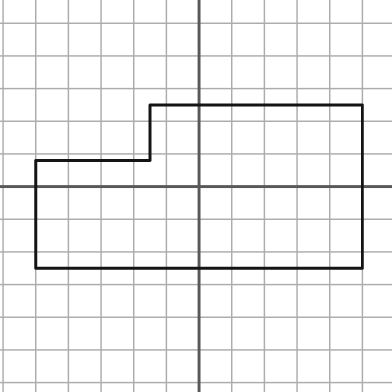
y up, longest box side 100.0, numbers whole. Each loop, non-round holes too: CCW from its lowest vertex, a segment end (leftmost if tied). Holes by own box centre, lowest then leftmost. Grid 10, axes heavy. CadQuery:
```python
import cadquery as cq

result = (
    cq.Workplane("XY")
    .moveTo(-50.0, -25.0)
    .lineTo(50.0, -25.0)
    .lineTo(50.0, 25.0)
    .lineTo(-15.0, 25.0)
    .lineTo(-15.0, 8.0)
    .lineTo(-50.0, 8.0)
    .close()
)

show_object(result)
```